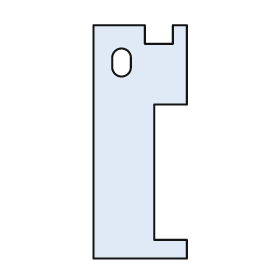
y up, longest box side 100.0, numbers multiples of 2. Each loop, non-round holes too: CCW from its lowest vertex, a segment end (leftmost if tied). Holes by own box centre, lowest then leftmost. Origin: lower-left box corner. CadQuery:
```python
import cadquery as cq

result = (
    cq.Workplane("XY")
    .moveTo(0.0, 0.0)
    .lineTo(40.0, 0.0)
    .lineTo(40.0, 8.0)
    .lineTo(26.0, 8.0)
    .lineTo(26.0, 66.0)
    .lineTo(40.0, 66.0)
    .lineTo(40.0, 100.0)
    .lineTo(34.0, 100.0)
    .lineTo(34.0, 92.0)
    .lineTo(22.0, 92.0)
    .lineTo(22.0, 100.0)
    .lineTo(0.0, 100.0)
    .close()
    .moveTo(8.0, 82.0)
    .threePointArc((12.0, 78.0), (16.0, 82.0))
    .lineTo(16.0, 86.0)
    .threePointArc((12.0, 90.0), (8.0, 86.0))
    .close()
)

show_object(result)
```